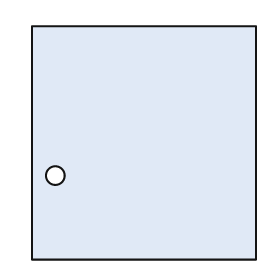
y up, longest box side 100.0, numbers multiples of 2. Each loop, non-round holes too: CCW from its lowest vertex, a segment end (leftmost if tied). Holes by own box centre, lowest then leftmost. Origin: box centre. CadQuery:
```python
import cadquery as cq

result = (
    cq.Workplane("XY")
    .moveTo(-48.0, -50.0)
    .lineTo(48.0, -50.0)
    .lineTo(48.0, 50.0)
    .lineTo(-48.0, 50.0)
    .close()
    .moveTo(-38.0, -14.0)
    .circle(4.0)
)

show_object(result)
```